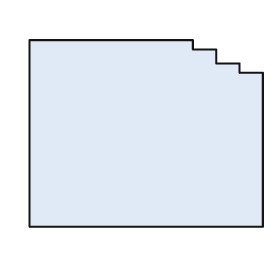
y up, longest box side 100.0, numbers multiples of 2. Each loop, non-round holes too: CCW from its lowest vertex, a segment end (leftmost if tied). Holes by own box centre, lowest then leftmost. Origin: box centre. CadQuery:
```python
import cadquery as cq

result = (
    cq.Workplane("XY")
    .moveTo(-50.0, -40.0)
    .lineTo(50.0, -40.0)
    .lineTo(50.0, 26.0)
    .lineTo(40.0, 26.0)
    .lineTo(40.0, 30.0)
    .lineTo(30.0, 30.0)
    .lineTo(30.0, 36.0)
    .lineTo(20.0, 36.0)
    .lineTo(20.0, 40.0)
    .lineTo(-50.0, 40.0)
    .close()
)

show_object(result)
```